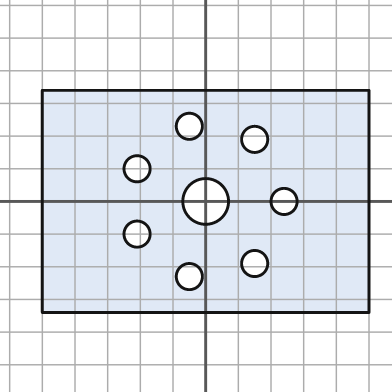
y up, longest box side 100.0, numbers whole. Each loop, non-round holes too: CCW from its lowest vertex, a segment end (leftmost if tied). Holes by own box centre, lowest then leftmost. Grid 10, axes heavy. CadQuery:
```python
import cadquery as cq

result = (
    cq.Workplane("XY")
    .moveTo(-50.0, -34.0)
    .lineTo(50.0, -34.0)
    .lineTo(50.0, 34.0)
    .lineTo(-50.0, 34.0)
    .close()
    .moveTo(-5.0, -23.0)
    .circle(4.0)
    .moveTo(15.0, -19.0)
    .circle(4.0)
    .moveTo(-21.0, -10.0)
    .circle(4.0)
    .moveTo(0.0, 0.0)
    .circle(7.0)
    .moveTo(24.0, 0.0)
    .circle(4.0)
    .moveTo(-21.0, 10.0)
    .circle(4.0)
    .moveTo(15.0, 19.0)
    .circle(4.0)
    .moveTo(-5.0, 23.0)
    .circle(4.0)
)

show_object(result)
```